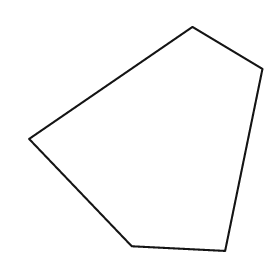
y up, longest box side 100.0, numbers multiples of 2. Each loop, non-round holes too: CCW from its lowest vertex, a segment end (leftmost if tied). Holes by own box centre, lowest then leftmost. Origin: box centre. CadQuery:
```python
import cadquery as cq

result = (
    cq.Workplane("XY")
    .moveTo(34.0, -48.0)
    .lineTo(50.0, 30.0)
    .lineTo(20.0, 48.0)
    .lineTo(-50.0, 0.0)
    .lineTo(-6.0, -46.0)
    .close()
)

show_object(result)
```